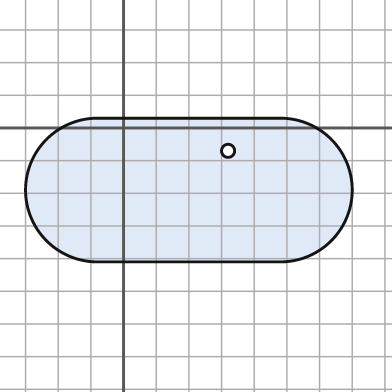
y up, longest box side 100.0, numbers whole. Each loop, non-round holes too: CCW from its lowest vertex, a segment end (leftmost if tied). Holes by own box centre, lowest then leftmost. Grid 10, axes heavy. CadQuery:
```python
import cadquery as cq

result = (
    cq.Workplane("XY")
    .moveTo(-8.0, -41.0)
    .lineTo(48.0, -41.0)
    .threePointArc((70.0, -19.0), (48.0, 3.0))
    .lineTo(-8.0, 3.0)
    .threePointArc((-30.0, -19.0), (-8.0, -41.0))
    .close()
    .moveTo(32.0, -7.0)
    .circle(2.0)
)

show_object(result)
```